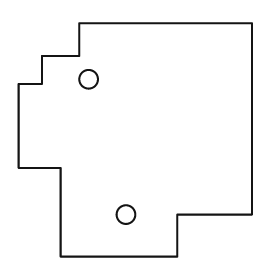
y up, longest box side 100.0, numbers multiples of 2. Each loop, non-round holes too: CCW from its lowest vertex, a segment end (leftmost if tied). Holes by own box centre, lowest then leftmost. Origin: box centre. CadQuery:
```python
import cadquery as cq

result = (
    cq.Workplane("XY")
    .moveTo(-32.0, -50.0)
    .lineTo(18.0, -50.0)
    .lineTo(18.0, -32.0)
    .lineTo(50.0, -32.0)
    .lineTo(50.0, 50.0)
    .lineTo(-24.0, 50.0)
    .lineTo(-24.0, 36.0)
    .lineTo(-40.0, 36.0)
    .lineTo(-40.0, 24.0)
    .lineTo(-50.0, 24.0)
    .lineTo(-50.0, -12.0)
    .lineTo(-32.0, -12.0)
    .close()
    .moveTo(-4.0, -32.0)
    .circle(4.0)
    .moveTo(-20.0, 26.0)
    .circle(4.0)
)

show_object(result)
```